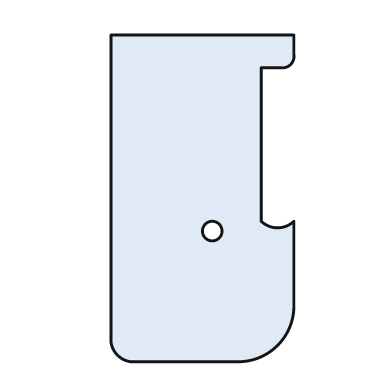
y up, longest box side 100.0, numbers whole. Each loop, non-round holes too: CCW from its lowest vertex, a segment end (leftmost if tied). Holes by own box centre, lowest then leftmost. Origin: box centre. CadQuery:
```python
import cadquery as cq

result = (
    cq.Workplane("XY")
    .moveTo(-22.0, -50.0)
    .lineTo(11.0, -50.0)
    .threePointArc((23.0, -45.0), (28.0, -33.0))
    .lineTo(28.0, -7.0)
    .threePointArc((23.0, -9.0), (18.0, -7.0))
    .lineTo(18.0, 40.0)
    .lineTo(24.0, 40.0)
    .threePointArc((27.0, 41.0), (28.0, 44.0))
    .lineTo(28.0, 50.0)
    .lineTo(-28.0, 50.0)
    .lineTo(-28.0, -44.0)
    .threePointArc((-26.0, -48.0), (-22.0, -50.0))
    .close()
    .moveTo(3.0, -10.0)
    .circle(3.0)
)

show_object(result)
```